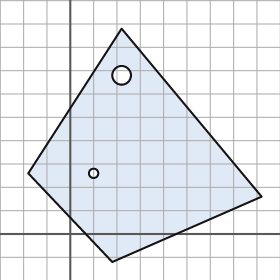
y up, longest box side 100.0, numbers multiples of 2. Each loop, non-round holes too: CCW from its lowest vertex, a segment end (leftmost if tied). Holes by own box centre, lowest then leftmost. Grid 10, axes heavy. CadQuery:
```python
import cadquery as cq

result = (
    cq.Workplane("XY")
    .moveTo(18.0, -12.0)
    .lineTo(82.0, 16.0)
    .lineTo(22.0, 88.0)
    .lineTo(-18.0, 26.0)
    .close()
    .moveTo(10.0, 26.0)
    .circle(2.0)
    .moveTo(22.0, 68.0)
    .circle(4.0)
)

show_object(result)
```